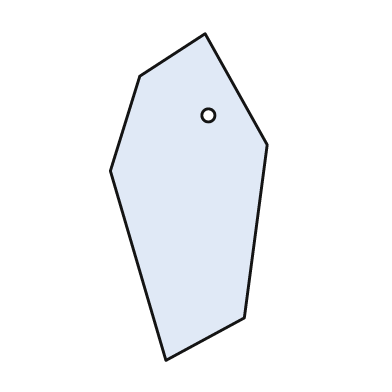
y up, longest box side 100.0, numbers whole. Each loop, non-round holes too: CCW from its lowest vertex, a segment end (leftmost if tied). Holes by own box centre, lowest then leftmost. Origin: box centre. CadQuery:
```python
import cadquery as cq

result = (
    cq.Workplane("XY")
    .moveTo(-7.0, -50.0)
    .lineTo(17.0, -37.0)
    .lineTo(24.0, 16.0)
    .lineTo(5.0, 50.0)
    .lineTo(-15.0, 37.0)
    .lineTo(-24.0, 8.0)
    .close()
    .moveTo(6.0, 25.0)
    .circle(2.0)
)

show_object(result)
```